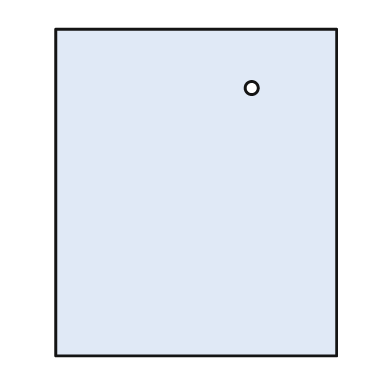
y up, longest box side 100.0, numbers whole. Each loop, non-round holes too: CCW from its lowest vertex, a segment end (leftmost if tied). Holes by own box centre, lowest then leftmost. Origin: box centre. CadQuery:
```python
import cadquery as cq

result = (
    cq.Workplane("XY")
    .moveTo(-43.0, -50.0)
    .lineTo(43.0, -50.0)
    .lineTo(43.0, 50.0)
    .lineTo(-43.0, 50.0)
    .close()
    .moveTo(17.0, 32.0)
    .circle(2.0)
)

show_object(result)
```